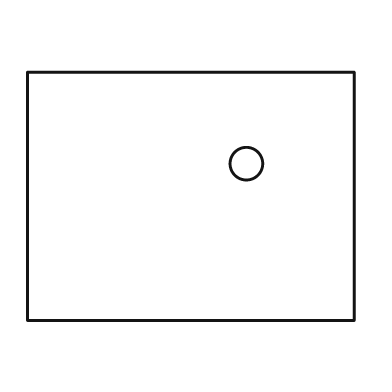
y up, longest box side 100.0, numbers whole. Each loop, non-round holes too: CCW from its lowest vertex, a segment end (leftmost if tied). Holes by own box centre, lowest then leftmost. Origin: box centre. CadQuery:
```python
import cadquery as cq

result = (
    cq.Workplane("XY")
    .moveTo(-50.0, -38.0)
    .lineTo(50.0, -38.0)
    .lineTo(50.0, 38.0)
    .lineTo(-50.0, 38.0)
    .close()
    .moveTo(17.0, 10.0)
    .circle(5.0)
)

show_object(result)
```